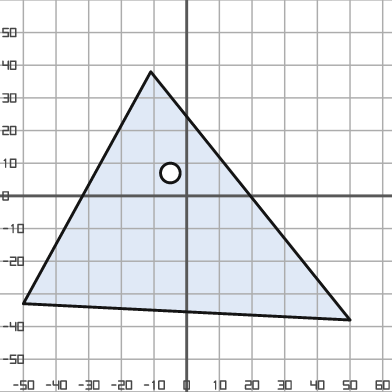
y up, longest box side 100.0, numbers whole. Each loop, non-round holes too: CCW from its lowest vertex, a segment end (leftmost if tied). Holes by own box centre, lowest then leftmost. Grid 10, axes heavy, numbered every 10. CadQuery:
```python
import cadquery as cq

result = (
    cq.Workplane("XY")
    .moveTo(50.0, -38.0)
    .lineTo(-11.0, 38.0)
    .lineTo(-50.0, -33.0)
    .close()
    .moveTo(-5.0, 7.0)
    .circle(3.0)
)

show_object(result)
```